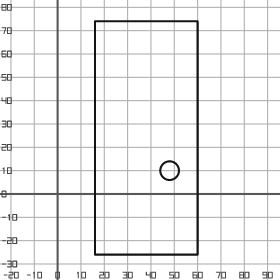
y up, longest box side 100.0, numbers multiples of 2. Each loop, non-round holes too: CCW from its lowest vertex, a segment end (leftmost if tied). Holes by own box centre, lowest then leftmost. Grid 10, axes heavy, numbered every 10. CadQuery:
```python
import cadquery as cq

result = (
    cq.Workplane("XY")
    .moveTo(16.0, -26.0)
    .lineTo(60.0, -26.0)
    .lineTo(60.0, 74.0)
    .lineTo(16.0, 74.0)
    .close()
    .moveTo(48.0, 10.0)
    .circle(4.0)
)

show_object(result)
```